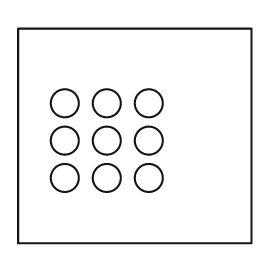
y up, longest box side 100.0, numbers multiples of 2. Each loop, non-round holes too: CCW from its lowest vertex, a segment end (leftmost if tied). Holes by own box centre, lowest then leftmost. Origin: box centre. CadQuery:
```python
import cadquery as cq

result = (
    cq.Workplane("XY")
    .moveTo(-50.0, -46.0)
    .lineTo(50.0, -46.0)
    .lineTo(50.0, 46.0)
    .lineTo(-50.0, 46.0)
    .close()
    .moveTo(-30.0, -18.0)
    .circle(6.0)
    .moveTo(-12.0, -18.0)
    .circle(6.0)
    .moveTo(6.0, -18.0)
    .circle(6.0)
    .moveTo(-30.0, -2.0)
    .circle(6.0)
    .moveTo(-12.0, -2.0)
    .circle(6.0)
    .moveTo(6.0, -2.0)
    .circle(6.0)
    .moveTo(-30.0, 14.0)
    .circle(6.0)
    .moveTo(-12.0, 14.0)
    .circle(6.0)
    .moveTo(6.0, 14.0)
    .circle(6.0)
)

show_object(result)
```